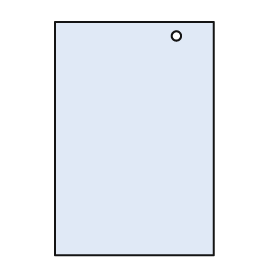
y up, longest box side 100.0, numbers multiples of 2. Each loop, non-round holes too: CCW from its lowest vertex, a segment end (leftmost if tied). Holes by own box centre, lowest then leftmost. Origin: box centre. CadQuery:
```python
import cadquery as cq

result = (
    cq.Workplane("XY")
    .moveTo(-34.0, -50.0)
    .lineTo(34.0, -50.0)
    .lineTo(34.0, 50.0)
    .lineTo(-34.0, 50.0)
    .close()
    .moveTo(18.0, 44.0)
    .circle(2.0)
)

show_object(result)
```